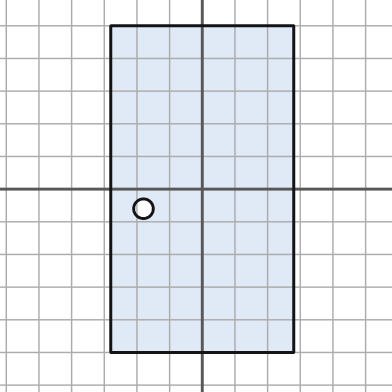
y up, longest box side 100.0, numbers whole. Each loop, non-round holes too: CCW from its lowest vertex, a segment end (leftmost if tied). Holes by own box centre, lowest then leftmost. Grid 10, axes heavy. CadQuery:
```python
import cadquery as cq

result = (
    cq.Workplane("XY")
    .moveTo(-28.0, -50.0)
    .lineTo(28.0, -50.0)
    .lineTo(28.0, 50.0)
    .lineTo(-28.0, 50.0)
    .close()
    .moveTo(-18.0, -6.0)
    .circle(3.0)
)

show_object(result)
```